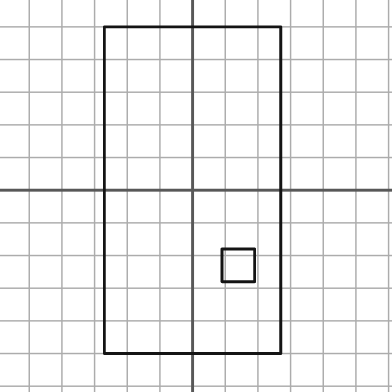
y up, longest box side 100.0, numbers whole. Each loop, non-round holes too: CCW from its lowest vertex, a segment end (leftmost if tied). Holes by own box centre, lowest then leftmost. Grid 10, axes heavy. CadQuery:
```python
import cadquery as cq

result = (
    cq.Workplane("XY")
    .moveTo(-27.0, -50.0)
    .lineTo(27.0, -50.0)
    .lineTo(27.0, 50.0)
    .lineTo(-27.0, 50.0)
    .close()
    .moveTo(9.0, -28.0)
    .lineTo(19.0, -28.0)
    .lineTo(19.0, -18.0)
    .lineTo(9.0, -18.0)
    .close()
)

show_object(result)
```